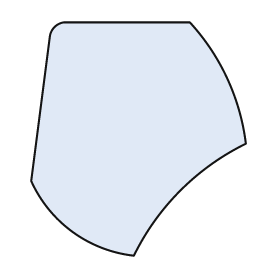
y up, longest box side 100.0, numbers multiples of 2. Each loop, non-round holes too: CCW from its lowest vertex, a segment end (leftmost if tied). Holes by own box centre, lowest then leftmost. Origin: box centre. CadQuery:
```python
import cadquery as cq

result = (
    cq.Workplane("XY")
    .moveTo(-2.0, -50.0)
    .threePointArc((18.0, -22.0), (46.0, -2.0))
    .threePointArc((38.0, 26.0), (22.0, 50.0))
    .lineTo(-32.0, 50.0)
    .threePointArc((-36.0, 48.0), (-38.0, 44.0))
    .lineTo(-46.0, -18.0)
    .threePointArc((-28.0, -40.0), (-2.0, -50.0))
    .close()
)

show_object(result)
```